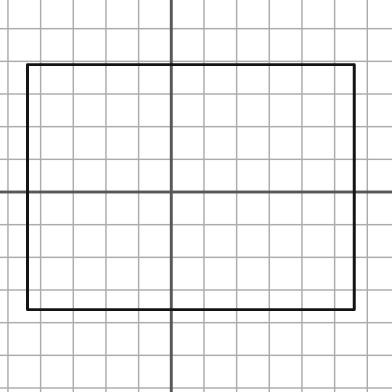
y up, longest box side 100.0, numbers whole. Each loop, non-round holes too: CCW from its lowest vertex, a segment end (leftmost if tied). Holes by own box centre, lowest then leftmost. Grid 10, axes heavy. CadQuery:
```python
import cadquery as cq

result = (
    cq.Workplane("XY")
    .moveTo(-44.0, -36.0)
    .lineTo(56.0, -36.0)
    .lineTo(56.0, 39.0)
    .lineTo(-44.0, 39.0)
    .close()
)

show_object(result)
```